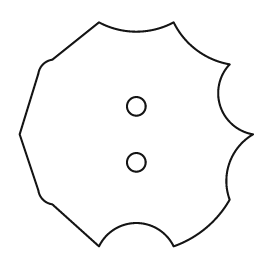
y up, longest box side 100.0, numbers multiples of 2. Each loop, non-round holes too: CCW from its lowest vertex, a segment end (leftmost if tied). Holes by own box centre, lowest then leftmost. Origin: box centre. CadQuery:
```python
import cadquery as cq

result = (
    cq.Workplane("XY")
    .moveTo(-16.0, -48.0)
    .threePointArc((0.0, -38.0), (16.0, -48.0))
    .threePointArc((30.0, -40.0), (40.0, -28.0))
    .threePointArc((40.0, -12.0), (50.0, 0.0))
    .threePointArc((36.0, 12.0), (40.0, 30.0))
    .threePointArc((26.0, 36.0), (16.0, 48.0))
    .threePointArc((0.0, 44.0), (-16.0, 48.0))
    .lineTo(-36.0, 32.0)
    .threePointArc((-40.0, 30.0), (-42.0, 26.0))
    .lineTo(-50.0, 0.0)
    .lineTo(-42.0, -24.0)
    .threePointArc((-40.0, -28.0), (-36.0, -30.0))
    .close()
    .moveTo(0.0, -12.0)
    .circle(4.0)
    .moveTo(0.0, 12.0)
    .circle(4.0)
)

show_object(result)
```